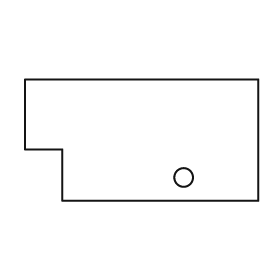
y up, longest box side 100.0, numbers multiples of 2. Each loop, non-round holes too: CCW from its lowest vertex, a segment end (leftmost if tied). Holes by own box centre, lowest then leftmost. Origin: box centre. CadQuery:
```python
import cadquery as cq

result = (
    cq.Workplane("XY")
    .moveTo(-34.0, -26.0)
    .lineTo(50.0, -26.0)
    .lineTo(50.0, 26.0)
    .lineTo(-50.0, 26.0)
    .lineTo(-50.0, -4.0)
    .lineTo(-34.0, -4.0)
    .close()
    .moveTo(18.0, -16.0)
    .circle(4.0)
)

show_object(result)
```